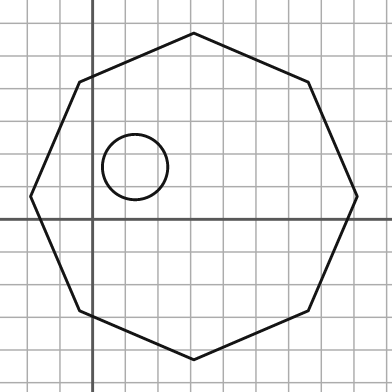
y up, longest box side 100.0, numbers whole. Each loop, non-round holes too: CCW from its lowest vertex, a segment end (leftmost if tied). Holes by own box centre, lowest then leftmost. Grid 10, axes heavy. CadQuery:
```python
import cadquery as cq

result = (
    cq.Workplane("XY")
    .moveTo(31.0, -43.0)
    .lineTo(66.0, -28.0)
    .lineTo(81.0, 7.0)
    .lineTo(66.0, 42.0)
    .lineTo(31.0, 57.0)
    .lineTo(-4.0, 42.0)
    .lineTo(-19.0, 7.0)
    .lineTo(-4.0, -28.0)
    .close()
    .moveTo(13.0, 16.0)
    .circle(10.0)
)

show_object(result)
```